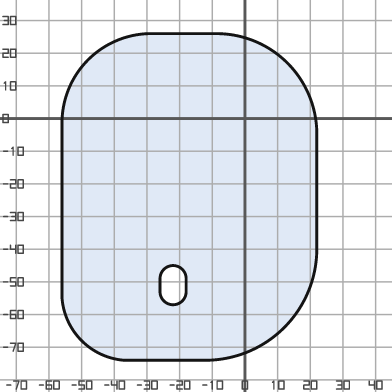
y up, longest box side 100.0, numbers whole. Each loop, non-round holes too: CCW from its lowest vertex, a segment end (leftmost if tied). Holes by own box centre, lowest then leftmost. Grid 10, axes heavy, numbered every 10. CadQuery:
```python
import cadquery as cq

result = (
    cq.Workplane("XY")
    .moveTo(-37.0, -74.0)
    .lineTo(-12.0, -74.0)
    .threePointArc((12.0, -64.0), (22.0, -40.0))
    .lineTo(22.0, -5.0)
    .threePointArc((13.0, 17.0), (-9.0, 26.0))
    .lineTo(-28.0, 26.0)
    .threePointArc((-48.0, 18.0), (-56.0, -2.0))
    .lineTo(-56.0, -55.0)
    .threePointArc((-50.0, -68.0), (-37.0, -74.0))
    .close()
    .moveTo(-26.0, -53.0)
    .threePointArc((-22.0, -57.0), (-18.0, -53.0))
    .lineTo(-18.0, -49.0)
    .threePointArc((-22.0, -45.0), (-26.0, -49.0))
    .close()
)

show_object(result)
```